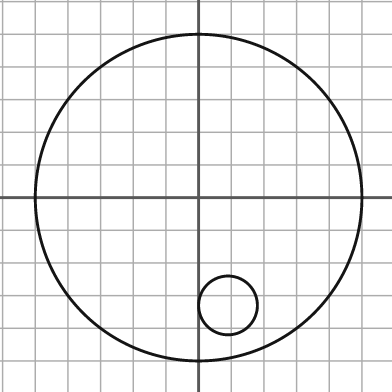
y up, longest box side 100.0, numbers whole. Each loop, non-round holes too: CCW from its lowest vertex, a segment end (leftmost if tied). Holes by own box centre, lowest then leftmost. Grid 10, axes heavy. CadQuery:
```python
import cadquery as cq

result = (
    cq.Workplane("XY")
    .moveTo(0.0, 0.0)
    .circle(50.0)
    .moveTo(9.0, -33.0)
    .circle(9.0)
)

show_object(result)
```